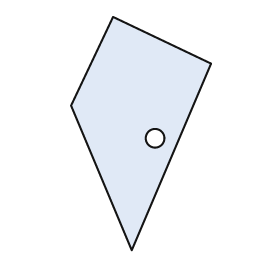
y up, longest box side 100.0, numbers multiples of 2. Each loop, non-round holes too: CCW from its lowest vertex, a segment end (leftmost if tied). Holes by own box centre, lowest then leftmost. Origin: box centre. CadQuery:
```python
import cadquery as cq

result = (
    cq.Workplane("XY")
    .moveTo(-4.0, -50.0)
    .lineTo(30.0, 30.0)
    .lineTo(-12.0, 50.0)
    .lineTo(-30.0, 12.0)
    .close()
    .moveTo(6.0, -2.0)
    .circle(4.0)
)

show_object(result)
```